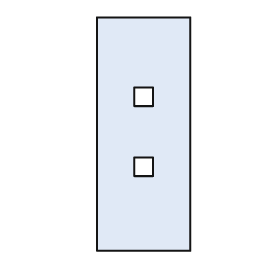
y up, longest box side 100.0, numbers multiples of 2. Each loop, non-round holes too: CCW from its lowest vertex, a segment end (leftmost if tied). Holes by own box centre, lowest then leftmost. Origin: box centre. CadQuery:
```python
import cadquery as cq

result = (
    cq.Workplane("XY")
    .moveTo(-20.0, -50.0)
    .lineTo(20.0, -50.0)
    .lineTo(20.0, 50.0)
    .lineTo(-20.0, 50.0)
    .close()
    .moveTo(-4.0, -18.0)
    .lineTo(4.0, -18.0)
    .lineTo(4.0, -10.0)
    .lineTo(-4.0, -10.0)
    .close()
    .moveTo(-4.0, 12.0)
    .lineTo(4.0, 12.0)
    .lineTo(4.0, 20.0)
    .lineTo(-4.0, 20.0)
    .close()
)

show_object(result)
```